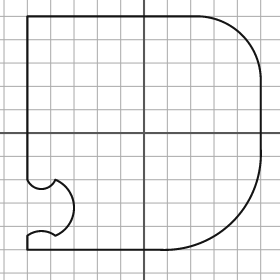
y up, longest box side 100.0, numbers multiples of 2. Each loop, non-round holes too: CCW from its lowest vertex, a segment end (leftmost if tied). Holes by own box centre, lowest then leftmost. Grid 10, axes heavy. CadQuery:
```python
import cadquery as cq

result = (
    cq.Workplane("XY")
    .moveTo(-50.0, -50.0)
    .lineTo(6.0, -50.0)
    .threePointArc((38.0, -38.0), (50.0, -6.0))
    .lineTo(50.0, 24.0)
    .threePointArc((42.0, 42.0), (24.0, 50.0))
    .lineTo(-50.0, 50.0)
    .lineTo(-50.0, -20.0)
    .threePointArc((-44.0, -24.0), (-38.0, -20.0))
    .threePointArc((-30.0, -32.0), (-38.0, -44.0))
    .threePointArc((-44.0, -42.0), (-50.0, -44.0))
    .close()
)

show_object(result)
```